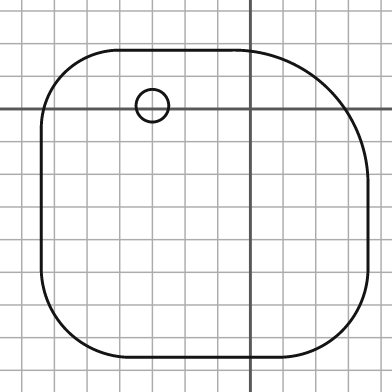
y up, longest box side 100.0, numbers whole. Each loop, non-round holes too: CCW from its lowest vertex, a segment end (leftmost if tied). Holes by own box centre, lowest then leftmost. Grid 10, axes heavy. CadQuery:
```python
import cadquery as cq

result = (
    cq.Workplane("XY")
    .moveTo(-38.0, -76.0)
    .lineTo(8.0, -76.0)
    .threePointArc((28.0, -68.0), (36.0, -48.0))
    .lineTo(36.0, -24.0)
    .threePointArc((24.0, 6.0), (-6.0, 18.0))
    .lineTo(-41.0, 18.0)
    .threePointArc((-57.0, 11.0), (-64.0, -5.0))
    .lineTo(-64.0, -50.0)
    .threePointArc((-56.0, -68.0), (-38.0, -76.0))
    .close()
    .moveTo(-30.0, 1.0)
    .circle(5.0)
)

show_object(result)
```